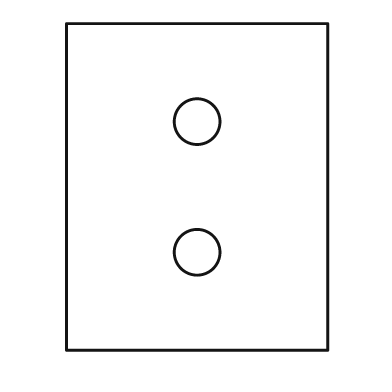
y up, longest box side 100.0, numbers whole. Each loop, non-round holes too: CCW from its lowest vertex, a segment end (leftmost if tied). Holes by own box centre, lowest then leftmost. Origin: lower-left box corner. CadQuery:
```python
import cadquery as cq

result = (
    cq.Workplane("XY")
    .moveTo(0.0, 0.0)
    .lineTo(80.0, 0.0)
    .lineTo(80.0, 100.0)
    .lineTo(0.0, 100.0)
    .close()
    .moveTo(40.0, 30.0)
    .circle(7.0)
    .moveTo(40.0, 70.0)
    .circle(7.0)
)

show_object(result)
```